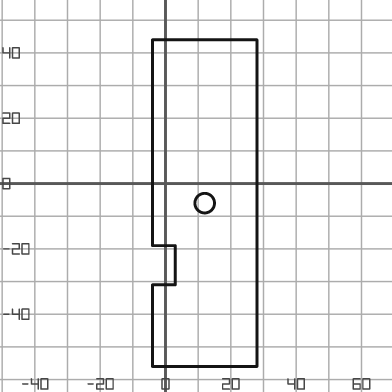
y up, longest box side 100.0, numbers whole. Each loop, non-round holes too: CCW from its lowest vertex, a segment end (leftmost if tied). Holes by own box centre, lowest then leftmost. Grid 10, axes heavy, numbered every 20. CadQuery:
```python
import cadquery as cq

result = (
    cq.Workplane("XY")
    .moveTo(-4.0, -56.0)
    .lineTo(28.0, -56.0)
    .lineTo(28.0, 44.0)
    .lineTo(-4.0, 44.0)
    .lineTo(-4.0, -19.0)
    .lineTo(3.0, -19.0)
    .lineTo(3.0, -31.0)
    .lineTo(-4.0, -31.0)
    .close()
    .moveTo(12.0, -6.0)
    .circle(3.0)
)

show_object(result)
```